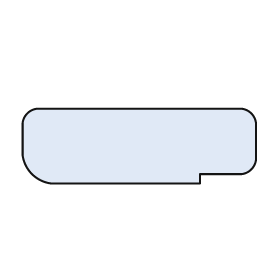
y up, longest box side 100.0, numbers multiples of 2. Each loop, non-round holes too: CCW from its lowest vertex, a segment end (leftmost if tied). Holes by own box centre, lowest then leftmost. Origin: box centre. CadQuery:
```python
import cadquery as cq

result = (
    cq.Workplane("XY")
    .moveTo(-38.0, -16.0)
    .lineTo(26.0, -16.0)
    .lineTo(26.0, -12.0)
    .lineTo(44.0, -12.0)
    .threePointArc((48.0, -10.0), (50.0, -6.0))
    .lineTo(50.0, 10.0)
    .threePointArc((48.0, 14.0), (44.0, 16.0))
    .lineTo(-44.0, 16.0)
    .threePointArc((-48.0, 14.0), (-50.0, 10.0))
    .lineTo(-50.0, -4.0)
    .threePointArc((-46.0, -12.0), (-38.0, -16.0))
    .close()
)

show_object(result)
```